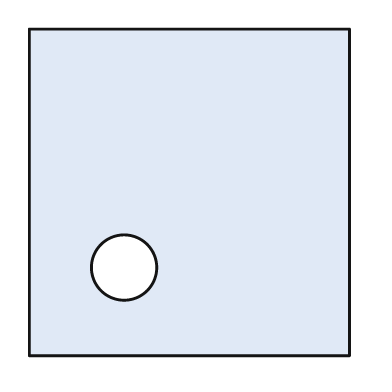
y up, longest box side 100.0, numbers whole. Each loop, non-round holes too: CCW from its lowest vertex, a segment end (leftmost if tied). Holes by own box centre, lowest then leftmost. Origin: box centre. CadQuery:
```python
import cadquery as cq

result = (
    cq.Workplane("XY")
    .moveTo(-49.0, -50.0)
    .lineTo(49.0, -50.0)
    .lineTo(49.0, 50.0)
    .lineTo(-49.0, 50.0)
    .close()
    .moveTo(-20.0, -23.0)
    .circle(10.0)
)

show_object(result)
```